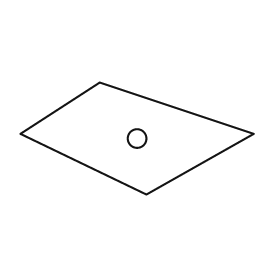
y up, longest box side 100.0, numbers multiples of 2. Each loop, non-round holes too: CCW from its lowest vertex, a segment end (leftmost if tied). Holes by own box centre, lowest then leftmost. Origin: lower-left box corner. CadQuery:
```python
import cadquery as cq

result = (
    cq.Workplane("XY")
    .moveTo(54.0, 0.0)
    .lineTo(100.0, 26.0)
    .lineTo(34.0, 48.0)
    .lineTo(0.0, 26.0)
    .close()
    .moveTo(50.0, 24.0)
    .circle(4.0)
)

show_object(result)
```